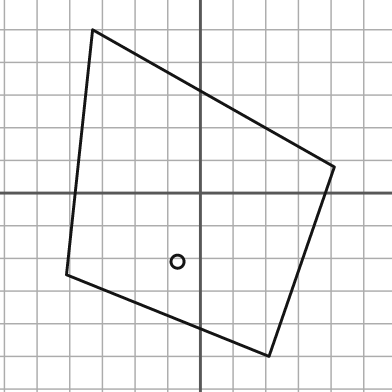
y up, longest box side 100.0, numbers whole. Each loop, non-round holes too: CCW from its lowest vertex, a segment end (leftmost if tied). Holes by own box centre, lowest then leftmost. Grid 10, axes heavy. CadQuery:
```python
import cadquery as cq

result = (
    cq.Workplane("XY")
    .moveTo(21.0, -50.0)
    .lineTo(41.0, 8.0)
    .lineTo(-33.0, 50.0)
    .lineTo(-41.0, -25.0)
    .close()
    .moveTo(-7.0, -21.0)
    .circle(2.0)
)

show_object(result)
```